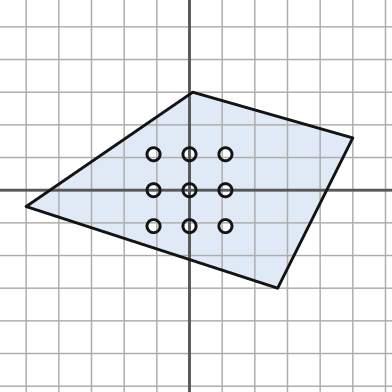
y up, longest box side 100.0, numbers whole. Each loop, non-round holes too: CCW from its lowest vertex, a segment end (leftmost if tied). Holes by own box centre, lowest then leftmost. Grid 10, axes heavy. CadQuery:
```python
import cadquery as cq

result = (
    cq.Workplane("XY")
    .moveTo(27.0, -30.0)
    .lineTo(50.0, 16.0)
    .lineTo(1.0, 30.0)
    .lineTo(-50.0, -5.0)
    .close()
    .moveTo(-11.0, -11.0)
    .circle(2.0)
    .moveTo(0.0, -11.0)
    .circle(2.0)
    .moveTo(11.0, -11.0)
    .circle(2.0)
    .moveTo(-11.0, 0.0)
    .circle(2.0)
    .moveTo(0.0, 0.0)
    .circle(2.0)
    .moveTo(11.0, 0.0)
    .circle(2.0)
    .moveTo(-11.0, 11.0)
    .circle(2.0)
    .moveTo(0.0, 11.0)
    .circle(2.0)
    .moveTo(11.0, 11.0)
    .circle(2.0)
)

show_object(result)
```